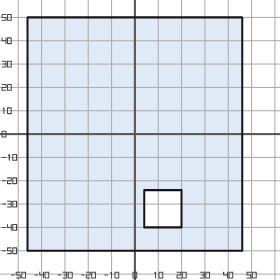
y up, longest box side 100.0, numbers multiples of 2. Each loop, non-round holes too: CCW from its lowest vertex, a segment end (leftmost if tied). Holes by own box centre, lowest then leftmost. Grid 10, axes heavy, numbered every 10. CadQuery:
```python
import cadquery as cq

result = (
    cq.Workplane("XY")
    .moveTo(-46.0, -50.0)
    .lineTo(46.0, -50.0)
    .lineTo(46.0, 50.0)
    .lineTo(-46.0, 50.0)
    .close()
    .moveTo(4.0, -40.0)
    .lineTo(20.0, -40.0)
    .lineTo(20.0, -24.0)
    .lineTo(4.0, -24.0)
    .close()
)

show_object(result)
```